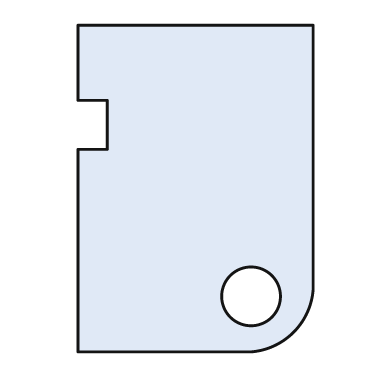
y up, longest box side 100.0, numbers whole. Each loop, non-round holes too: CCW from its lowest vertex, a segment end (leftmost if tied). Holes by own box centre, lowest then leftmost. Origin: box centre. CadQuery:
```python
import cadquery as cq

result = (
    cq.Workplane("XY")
    .moveTo(-36.0, -50.0)
    .lineTo(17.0, -50.0)
    .threePointArc((30.0, -44.0), (36.0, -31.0))
    .lineTo(36.0, 50.0)
    .lineTo(-36.0, 50.0)
    .lineTo(-36.0, 27.0)
    .lineTo(-27.0, 27.0)
    .lineTo(-27.0, 12.0)
    .lineTo(-36.0, 12.0)
    .close()
    .moveTo(17.0, -33.0)
    .circle(9.0)
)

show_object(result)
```